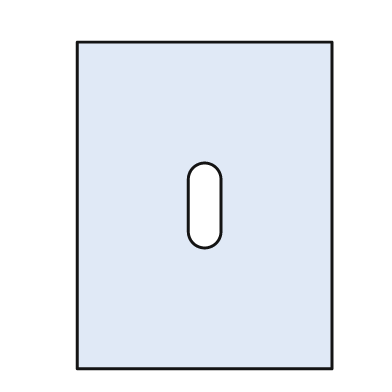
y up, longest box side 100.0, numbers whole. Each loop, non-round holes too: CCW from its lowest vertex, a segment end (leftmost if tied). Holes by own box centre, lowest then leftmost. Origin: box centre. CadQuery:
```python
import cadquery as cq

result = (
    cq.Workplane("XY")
    .moveTo(-39.0, -50.0)
    .lineTo(39.0, -50.0)
    .lineTo(39.0, 50.0)
    .lineTo(-39.0, 50.0)
    .close()
    .moveTo(-5.0, -8.0)
    .threePointArc((0.0, -13.0), (5.0, -8.0))
    .lineTo(5.0, 8.0)
    .threePointArc((0.0, 13.0), (-5.0, 8.0))
    .close()
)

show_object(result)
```